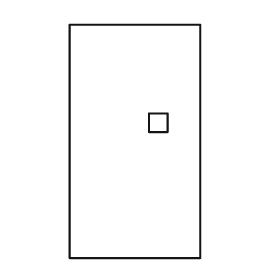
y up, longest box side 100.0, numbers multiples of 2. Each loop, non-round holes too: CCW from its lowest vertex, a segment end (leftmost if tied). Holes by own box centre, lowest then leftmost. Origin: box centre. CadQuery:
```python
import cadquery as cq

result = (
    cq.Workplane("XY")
    .moveTo(-28.0, -50.0)
    .lineTo(28.0, -50.0)
    .lineTo(28.0, 50.0)
    .lineTo(-28.0, 50.0)
    .close()
    .moveTo(6.0, 4.0)
    .lineTo(14.0, 4.0)
    .lineTo(14.0, 12.0)
    .lineTo(6.0, 12.0)
    .close()
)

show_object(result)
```